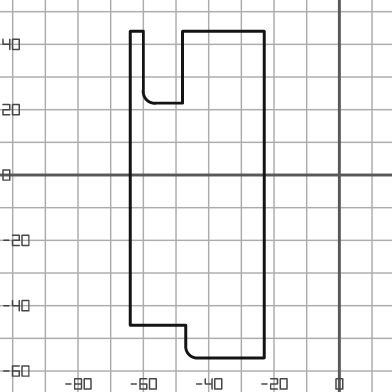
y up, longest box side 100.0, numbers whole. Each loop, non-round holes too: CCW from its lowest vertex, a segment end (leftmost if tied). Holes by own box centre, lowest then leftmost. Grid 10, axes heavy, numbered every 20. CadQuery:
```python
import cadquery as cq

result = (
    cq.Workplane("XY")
    .moveTo(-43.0, -56.0)
    .lineTo(-23.0, -56.0)
    .lineTo(-23.0, 44.0)
    .lineTo(-48.0, 44.0)
    .lineTo(-48.0, 22.0)
    .lineTo(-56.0, 22.0)
    .threePointArc((-59.0, 23.0), (-60.0, 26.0))
    .lineTo(-60.0, 44.0)
    .lineTo(-64.0, 44.0)
    .lineTo(-64.0, -46.0)
    .lineTo(-47.0, -46.0)
    .lineTo(-47.0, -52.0)
    .threePointArc((-46.0, -55.0), (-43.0, -56.0))
    .close()
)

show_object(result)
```